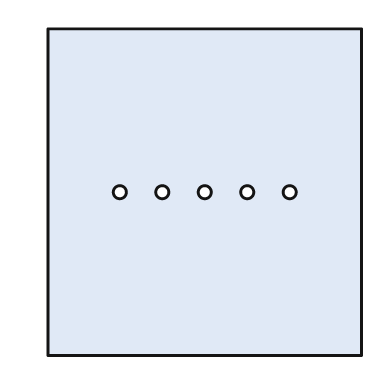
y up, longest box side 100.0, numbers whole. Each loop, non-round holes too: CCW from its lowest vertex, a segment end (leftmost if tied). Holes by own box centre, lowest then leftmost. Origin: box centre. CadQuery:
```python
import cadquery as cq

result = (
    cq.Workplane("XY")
    .moveTo(-48.0, -50.0)
    .lineTo(48.0, -50.0)
    .lineTo(48.0, 50.0)
    .lineTo(-48.0, 50.0)
    .close()
    .moveTo(-26.0, 0.0)
    .circle(2.0)
    .moveTo(-13.0, 0.0)
    .circle(2.0)
    .moveTo(0.0, 0.0)
    .circle(2.0)
    .moveTo(13.0, 0.0)
    .circle(2.0)
    .moveTo(26.0, 0.0)
    .circle(2.0)
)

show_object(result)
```